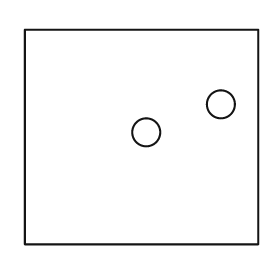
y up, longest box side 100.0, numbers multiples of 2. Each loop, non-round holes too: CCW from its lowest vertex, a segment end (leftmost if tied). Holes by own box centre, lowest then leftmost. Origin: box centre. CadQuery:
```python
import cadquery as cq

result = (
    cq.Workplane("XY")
    .moveTo(-50.0, -46.0)
    .lineTo(50.0, -46.0)
    .lineTo(50.0, 46.0)
    .lineTo(-50.0, 46.0)
    .close()
    .moveTo(2.0, 2.0)
    .circle(6.0)
    .moveTo(34.0, 14.0)
    .circle(6.0)
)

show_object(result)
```